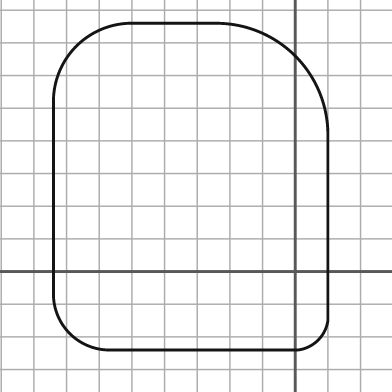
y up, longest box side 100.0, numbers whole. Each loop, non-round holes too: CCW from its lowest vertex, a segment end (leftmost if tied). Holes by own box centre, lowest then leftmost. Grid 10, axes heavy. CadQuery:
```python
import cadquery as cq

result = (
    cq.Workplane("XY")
    .moveTo(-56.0, -24.0)
    .lineTo(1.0, -24.0)
    .threePointArc((7.0, -21.0), (10.0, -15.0))
    .lineTo(10.0, 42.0)
    .threePointArc((0.0, 66.0), (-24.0, 76.0))
    .lineTo(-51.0, 76.0)
    .threePointArc((-67.0, 69.0), (-74.0, 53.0))
    .lineTo(-74.0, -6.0)
    .threePointArc((-69.0, -19.0), (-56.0, -24.0))
    .close()
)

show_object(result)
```